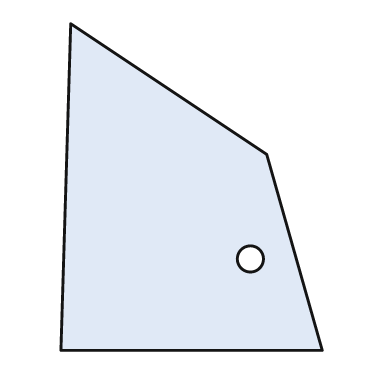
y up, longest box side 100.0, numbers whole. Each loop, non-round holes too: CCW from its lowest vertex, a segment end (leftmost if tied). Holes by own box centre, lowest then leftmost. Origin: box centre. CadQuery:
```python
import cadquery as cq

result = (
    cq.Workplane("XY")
    .moveTo(-40.0, -50.0)
    .lineTo(40.0, -50.0)
    .lineTo(23.0, 10.0)
    .lineTo(-37.0, 50.0)
    .close()
    .moveTo(18.0, -22.0)
    .circle(4.0)
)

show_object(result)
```